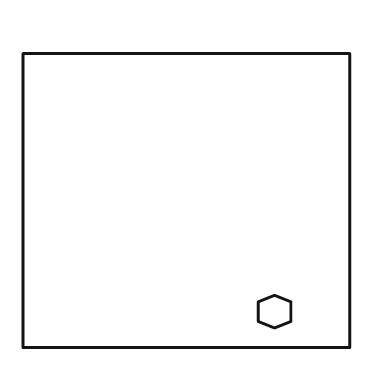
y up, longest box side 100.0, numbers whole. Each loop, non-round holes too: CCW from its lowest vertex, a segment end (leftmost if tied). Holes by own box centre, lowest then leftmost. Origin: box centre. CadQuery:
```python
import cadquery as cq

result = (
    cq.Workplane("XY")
    .moveTo(-50.0, -45.0)
    .lineTo(50.0, -45.0)
    .lineTo(50.0, 45.0)
    .lineTo(-50.0, 45.0)
    .close()
    .moveTo(27.0, -39.0)
    .lineTo(32.0, -37.0)
    .lineTo(32.0, -31.0)
    .lineTo(27.0, -29.0)
    .lineTo(22.0, -31.0)
    .lineTo(22.0, -37.0)
    .close()
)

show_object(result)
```